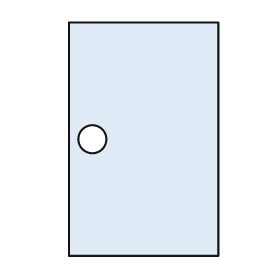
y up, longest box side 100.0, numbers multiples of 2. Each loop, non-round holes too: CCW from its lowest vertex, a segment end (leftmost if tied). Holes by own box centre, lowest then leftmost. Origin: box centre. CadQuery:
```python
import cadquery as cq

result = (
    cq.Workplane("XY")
    .moveTo(-32.0, -50.0)
    .lineTo(32.0, -50.0)
    .lineTo(32.0, 50.0)
    .lineTo(-32.0, 50.0)
    .close()
    .moveTo(-22.0, 0.0)
    .circle(6.0)
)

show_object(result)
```